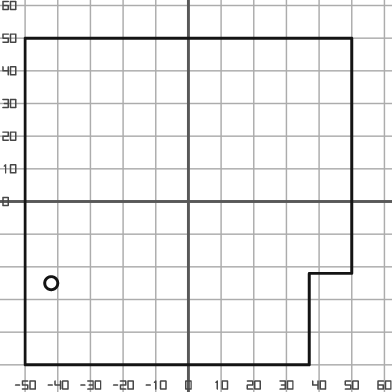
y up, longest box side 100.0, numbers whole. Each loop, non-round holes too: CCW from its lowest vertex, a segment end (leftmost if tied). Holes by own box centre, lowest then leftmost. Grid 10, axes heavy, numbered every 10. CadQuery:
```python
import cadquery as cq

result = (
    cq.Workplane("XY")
    .moveTo(-50.0, -50.0)
    .lineTo(37.0, -50.0)
    .lineTo(37.0, -22.0)
    .lineTo(50.0, -22.0)
    .lineTo(50.0, 50.0)
    .lineTo(-50.0, 50.0)
    .close()
    .moveTo(-42.0, -25.0)
    .circle(2.0)
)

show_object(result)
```